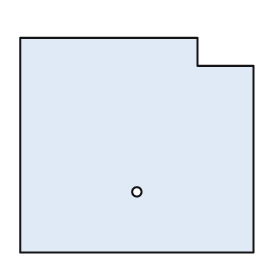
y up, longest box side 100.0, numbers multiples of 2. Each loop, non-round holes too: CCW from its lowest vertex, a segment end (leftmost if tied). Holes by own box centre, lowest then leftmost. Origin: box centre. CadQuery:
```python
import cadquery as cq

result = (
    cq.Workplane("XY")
    .moveTo(-50.0, -46.0)
    .lineTo(50.0, -46.0)
    .lineTo(50.0, 34.0)
    .lineTo(26.0, 34.0)
    .lineTo(26.0, 46.0)
    .lineTo(-50.0, 46.0)
    .close()
    .moveTo(0.0, -20.0)
    .circle(2.0)
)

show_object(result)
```